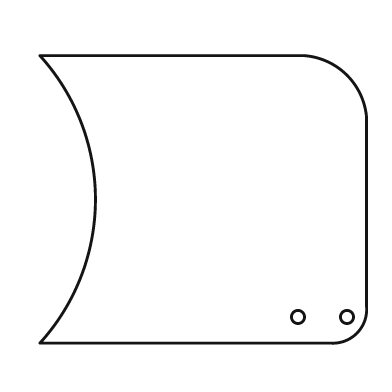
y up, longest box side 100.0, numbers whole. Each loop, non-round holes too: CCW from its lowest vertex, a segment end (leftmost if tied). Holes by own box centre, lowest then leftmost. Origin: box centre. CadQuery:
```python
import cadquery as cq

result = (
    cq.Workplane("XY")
    .moveTo(-50.0, -44.0)
    .lineTo(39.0, -44.0)
    .threePointArc((47.0, -41.0), (50.0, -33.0))
    .lineTo(50.0, 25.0)
    .threePointArc((44.0, 38.0), (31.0, 44.0))
    .lineTo(-50.0, 44.0)
    .threePointArc((-33.0, 0.0), (-50.0, -44.0))
    .close()
    .moveTo(29.0, -36.0)
    .circle(2.0)
    .moveTo(44.0, -36.0)
    .circle(2.0)
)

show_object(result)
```